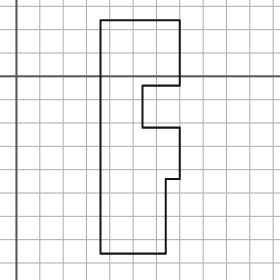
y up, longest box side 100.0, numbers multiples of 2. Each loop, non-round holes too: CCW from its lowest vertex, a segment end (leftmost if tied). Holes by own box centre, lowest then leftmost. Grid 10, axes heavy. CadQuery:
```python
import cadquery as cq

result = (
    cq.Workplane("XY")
    .moveTo(36.0, -76.0)
    .lineTo(64.0, -76.0)
    .lineTo(64.0, -44.0)
    .lineTo(70.0, -44.0)
    .lineTo(70.0, -22.0)
    .lineTo(54.0, -22.0)
    .lineTo(54.0, -4.0)
    .lineTo(70.0, -4.0)
    .lineTo(70.0, 24.0)
    .lineTo(36.0, 24.0)
    .close()
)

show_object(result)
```